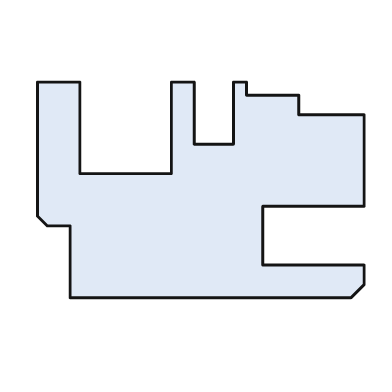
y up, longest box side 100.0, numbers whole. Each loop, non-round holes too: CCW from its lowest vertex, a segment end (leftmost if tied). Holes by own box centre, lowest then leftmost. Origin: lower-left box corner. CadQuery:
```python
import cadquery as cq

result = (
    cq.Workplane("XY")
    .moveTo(10.0, 0.0)
    .lineTo(96.0, 0.0)
    .lineTo(100.0, 4.0)
    .lineTo(100.0, 10.0)
    .lineTo(69.0, 10.0)
    .lineTo(69.0, 28.0)
    .lineTo(100.0, 28.0)
    .lineTo(100.0, 56.0)
    .lineTo(80.0, 56.0)
    .lineTo(80.0, 62.0)
    .lineTo(64.0, 62.0)
    .lineTo(64.0, 66.0)
    .lineTo(60.0, 66.0)
    .lineTo(60.0, 47.0)
    .lineTo(48.0, 47.0)
    .lineTo(48.0, 66.0)
    .lineTo(41.0, 66.0)
    .lineTo(41.0, 38.0)
    .lineTo(13.0, 38.0)
    .lineTo(13.0, 66.0)
    .lineTo(0.0, 66.0)
    .lineTo(0.0, 25.0)
    .lineTo(3.0, 22.0)
    .lineTo(10.0, 22.0)
    .close()
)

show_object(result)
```